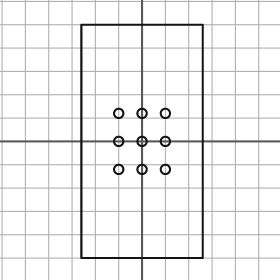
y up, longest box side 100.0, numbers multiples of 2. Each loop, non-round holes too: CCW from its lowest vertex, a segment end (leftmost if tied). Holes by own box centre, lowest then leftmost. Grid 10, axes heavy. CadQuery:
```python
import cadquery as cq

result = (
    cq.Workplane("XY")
    .moveTo(-26.0, -50.0)
    .lineTo(26.0, -50.0)
    .lineTo(26.0, 50.0)
    .lineTo(-26.0, 50.0)
    .close()
    .moveTo(-10.0, -12.0)
    .circle(2.0)
    .moveTo(0.0, -12.0)
    .circle(2.0)
    .moveTo(10.0, -12.0)
    .circle(2.0)
    .moveTo(-10.0, 0.0)
    .circle(2.0)
    .moveTo(0.0, 0.0)
    .circle(2.0)
    .moveTo(10.0, 0.0)
    .circle(2.0)
    .moveTo(-10.0, 12.0)
    .circle(2.0)
    .moveTo(0.0, 12.0)
    .circle(2.0)
    .moveTo(10.0, 12.0)
    .circle(2.0)
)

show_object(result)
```